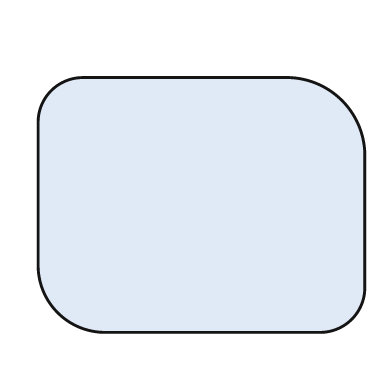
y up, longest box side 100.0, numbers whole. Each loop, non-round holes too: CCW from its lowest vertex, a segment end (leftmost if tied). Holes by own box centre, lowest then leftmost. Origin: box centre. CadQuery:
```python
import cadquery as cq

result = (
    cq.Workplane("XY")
    .moveTo(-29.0, -39.0)
    .lineTo(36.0, -39.0)
    .threePointArc((46.0, -35.0), (50.0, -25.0))
    .lineTo(50.0, 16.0)
    .threePointArc((43.0, 32.0), (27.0, 39.0))
    .lineTo(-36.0, 39.0)
    .threePointArc((-46.0, 35.0), (-50.0, 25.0))
    .lineTo(-50.0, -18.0)
    .threePointArc((-44.0, -33.0), (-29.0, -39.0))
    .close()
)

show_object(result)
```